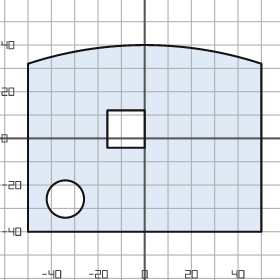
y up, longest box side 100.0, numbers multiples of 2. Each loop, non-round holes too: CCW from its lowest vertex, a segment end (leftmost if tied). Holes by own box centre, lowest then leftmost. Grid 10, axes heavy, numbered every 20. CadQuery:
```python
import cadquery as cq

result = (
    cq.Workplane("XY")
    .moveTo(-50.0, -40.0)
    .lineTo(50.0, -40.0)
    .lineTo(50.0, 32.0)
    .threePointArc((0.0, 40.0), (-50.0, 32.0))
    .close()
    .moveTo(-34.0, -26.0)
    .circle(8.0)
    .moveTo(-16.0, -4.0)
    .lineTo(0.0, -4.0)
    .lineTo(0.0, 12.0)
    .lineTo(-16.0, 12.0)
    .close()
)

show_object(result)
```